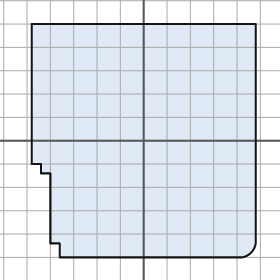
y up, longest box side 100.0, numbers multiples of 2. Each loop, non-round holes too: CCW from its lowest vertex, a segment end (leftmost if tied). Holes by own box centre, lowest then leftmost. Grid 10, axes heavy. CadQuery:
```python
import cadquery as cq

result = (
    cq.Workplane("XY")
    .moveTo(-36.0, -50.0)
    .lineTo(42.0, -50.0)
    .threePointArc((46.0, -48.0), (48.0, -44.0))
    .lineTo(48.0, 50.0)
    .lineTo(-48.0, 50.0)
    .lineTo(-48.0, -10.0)
    .lineTo(-44.0, -10.0)
    .lineTo(-44.0, -14.0)
    .lineTo(-40.0, -14.0)
    .lineTo(-40.0, -44.0)
    .lineTo(-36.0, -44.0)
    .close()
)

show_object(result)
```